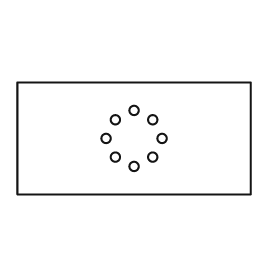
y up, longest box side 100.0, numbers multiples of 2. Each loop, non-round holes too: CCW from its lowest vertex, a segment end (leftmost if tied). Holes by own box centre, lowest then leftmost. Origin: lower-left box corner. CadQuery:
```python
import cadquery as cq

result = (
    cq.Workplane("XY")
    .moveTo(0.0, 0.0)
    .lineTo(100.0, 0.0)
    .lineTo(100.0, 48.0)
    .lineTo(0.0, 48.0)
    .close()
    .moveTo(50.0, 12.0)
    .circle(2.0)
    .moveTo(42.0, 16.0)
    .circle(2.0)
    .moveTo(58.0, 16.0)
    .circle(2.0)
    .moveTo(38.0, 24.0)
    .circle(2.0)
    .moveTo(62.0, 24.0)
    .circle(2.0)
    .moveTo(42.0, 32.0)
    .circle(2.0)
    .moveTo(58.0, 32.0)
    .circle(2.0)
    .moveTo(50.0, 36.0)
    .circle(2.0)
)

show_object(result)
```